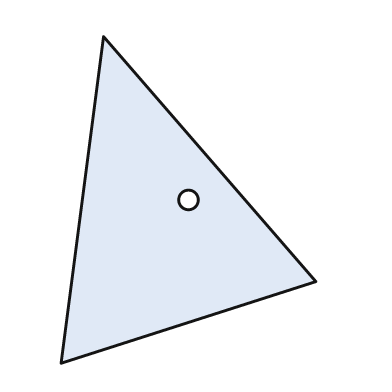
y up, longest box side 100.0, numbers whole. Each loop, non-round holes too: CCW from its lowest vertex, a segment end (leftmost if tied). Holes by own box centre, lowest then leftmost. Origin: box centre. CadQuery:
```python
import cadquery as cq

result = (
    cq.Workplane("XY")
    .moveTo(-39.0, -50.0)
    .lineTo(39.0, -25.0)
    .lineTo(-26.0, 50.0)
    .close()
    .moveTo(0.0, 0.0)
    .circle(3.0)
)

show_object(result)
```